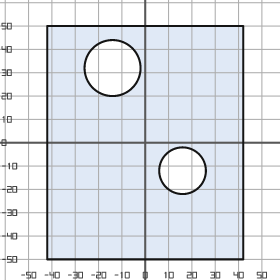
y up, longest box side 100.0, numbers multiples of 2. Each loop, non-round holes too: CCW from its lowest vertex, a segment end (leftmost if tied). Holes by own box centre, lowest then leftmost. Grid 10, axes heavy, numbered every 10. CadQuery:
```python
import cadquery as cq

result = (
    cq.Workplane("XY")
    .moveTo(-42.0, -50.0)
    .lineTo(42.0, -50.0)
    .lineTo(42.0, 50.0)
    .lineTo(-42.0, 50.0)
    .close()
    .moveTo(16.0, -12.0)
    .circle(10.0)
    .moveTo(-14.0, 32.0)
    .circle(12.0)
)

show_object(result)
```